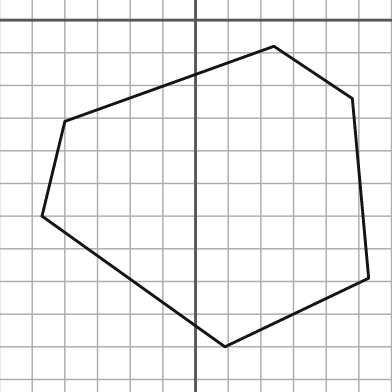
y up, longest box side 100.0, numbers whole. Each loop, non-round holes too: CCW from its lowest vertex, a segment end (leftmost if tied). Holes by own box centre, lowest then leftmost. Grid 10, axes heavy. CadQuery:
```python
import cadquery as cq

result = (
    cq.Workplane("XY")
    .moveTo(9.0, -100.0)
    .lineTo(53.0, -79.0)
    .lineTo(48.0, -24.0)
    .lineTo(24.0, -8.0)
    .lineTo(-40.0, -31.0)
    .lineTo(-47.0, -60.0)
    .close()
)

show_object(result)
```